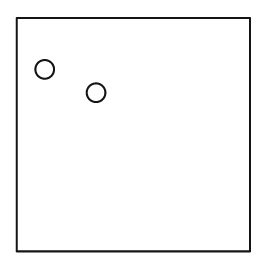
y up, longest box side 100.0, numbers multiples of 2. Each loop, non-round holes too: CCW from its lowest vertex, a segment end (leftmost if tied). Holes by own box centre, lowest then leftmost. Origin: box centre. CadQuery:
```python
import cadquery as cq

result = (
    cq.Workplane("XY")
    .moveTo(-50.0, -50.0)
    .lineTo(50.0, -50.0)
    .lineTo(50.0, 50.0)
    .lineTo(-50.0, 50.0)
    .close()
    .moveTo(-16.0, 18.0)
    .circle(4.0)
    .moveTo(-38.0, 28.0)
    .circle(4.0)
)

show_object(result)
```